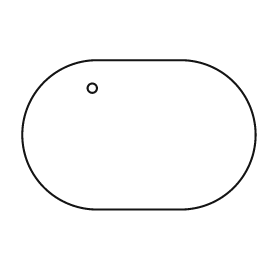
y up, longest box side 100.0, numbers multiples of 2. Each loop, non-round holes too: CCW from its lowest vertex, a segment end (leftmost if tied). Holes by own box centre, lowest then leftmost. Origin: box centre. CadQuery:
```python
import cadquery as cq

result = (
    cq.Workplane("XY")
    .moveTo(-18.0, -32.0)
    .lineTo(18.0, -32.0)
    .threePointArc((50.0, 0.0), (18.0, 32.0))
    .lineTo(-18.0, 32.0)
    .threePointArc((-50.0, 0.0), (-18.0, -32.0))
    .close()
    .moveTo(-20.0, 20.0)
    .circle(2.0)
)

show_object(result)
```